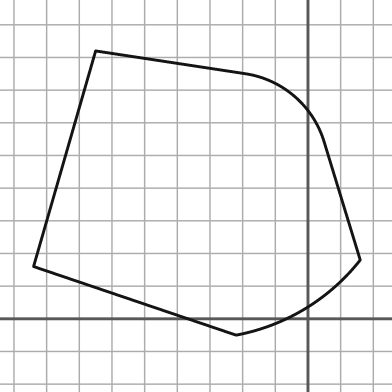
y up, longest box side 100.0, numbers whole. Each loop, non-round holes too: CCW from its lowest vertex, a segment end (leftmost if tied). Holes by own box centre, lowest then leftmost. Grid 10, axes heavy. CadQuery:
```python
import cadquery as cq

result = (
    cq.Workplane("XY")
    .moveTo(-22.0, -5.0)
    .threePointArc((-1.0, 3.0), (16.0, 18.0))
    .lineTo(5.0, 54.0)
    .threePointArc((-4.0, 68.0), (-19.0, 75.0))
    .lineTo(-65.0, 82.0)
    .lineTo(-84.0, 16.0)
    .close()
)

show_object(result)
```